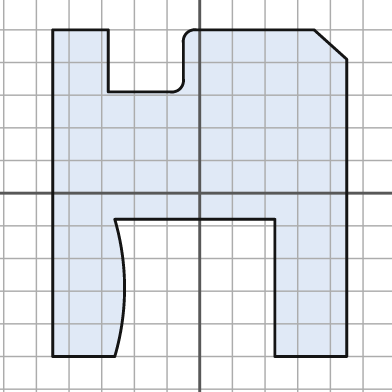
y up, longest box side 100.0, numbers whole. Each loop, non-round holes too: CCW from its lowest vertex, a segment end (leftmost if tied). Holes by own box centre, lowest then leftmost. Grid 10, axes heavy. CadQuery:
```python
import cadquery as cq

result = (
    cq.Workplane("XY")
    .moveTo(-45.0, -50.0)
    .lineTo(-26.0, -50.0)
    .threePointArc((-23.0, -29.0), (-26.0, -8.0))
    .lineTo(23.0, -8.0)
    .lineTo(23.0, -50.0)
    .lineTo(45.0, -50.0)
    .lineTo(45.0, 41.0)
    .lineTo(35.0, 50.0)
    .lineTo(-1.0, 50.0)
    .threePointArc((-4.0, 49.0), (-5.0, 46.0))
    .lineTo(-5.0, 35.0)
    .threePointArc((-6.0, 32.0), (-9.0, 31.0))
    .lineTo(-28.0, 31.0)
    .lineTo(-28.0, 50.0)
    .lineTo(-45.0, 50.0)
    .close()
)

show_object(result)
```